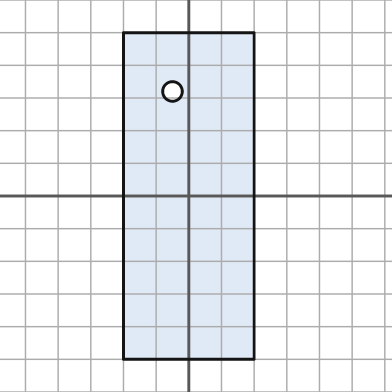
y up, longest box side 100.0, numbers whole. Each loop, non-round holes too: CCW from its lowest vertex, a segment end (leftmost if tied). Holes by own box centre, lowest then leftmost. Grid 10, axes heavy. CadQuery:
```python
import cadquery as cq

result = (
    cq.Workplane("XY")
    .moveTo(-20.0, -50.0)
    .lineTo(20.0, -50.0)
    .lineTo(20.0, 50.0)
    .lineTo(-20.0, 50.0)
    .close()
    .moveTo(-5.0, 32.0)
    .circle(3.0)
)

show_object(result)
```